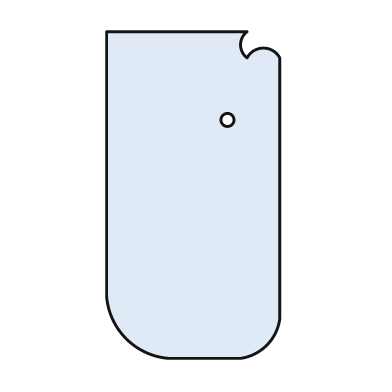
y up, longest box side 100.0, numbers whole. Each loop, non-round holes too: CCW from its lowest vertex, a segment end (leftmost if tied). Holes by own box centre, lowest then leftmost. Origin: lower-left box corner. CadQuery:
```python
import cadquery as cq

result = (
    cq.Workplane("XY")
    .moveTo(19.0, 0.0)
    .lineTo(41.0, 0.0)
    .threePointArc((49.0, 4.0), (53.0, 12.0))
    .lineTo(53.0, 92.0)
    .threePointArc((48.0, 95.0), (43.0, 92.0))
    .threePointArc((41.0, 96.0), (43.0, 100.0))
    .lineTo(0.0, 100.0)
    .lineTo(0.0, 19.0)
    .threePointArc((6.0, 6.0), (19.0, 0.0))
    .close()
    .moveTo(37.0, 73.0)
    .circle(2.0)
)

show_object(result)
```